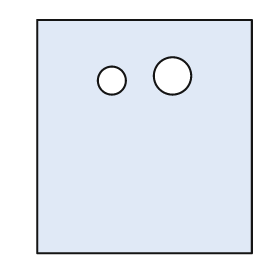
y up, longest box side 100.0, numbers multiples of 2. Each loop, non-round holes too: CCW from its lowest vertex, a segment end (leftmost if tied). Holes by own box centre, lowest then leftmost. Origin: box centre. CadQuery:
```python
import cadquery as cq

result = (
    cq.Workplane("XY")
    .moveTo(-46.0, -50.0)
    .lineTo(46.0, -50.0)
    .lineTo(46.0, 50.0)
    .lineTo(-46.0, 50.0)
    .close()
    .moveTo(-14.0, 24.0)
    .circle(6.0)
    .moveTo(12.0, 26.0)
    .circle(8.0)
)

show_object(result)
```